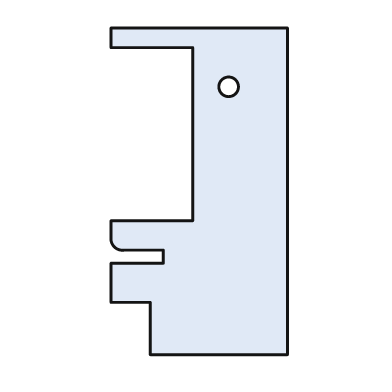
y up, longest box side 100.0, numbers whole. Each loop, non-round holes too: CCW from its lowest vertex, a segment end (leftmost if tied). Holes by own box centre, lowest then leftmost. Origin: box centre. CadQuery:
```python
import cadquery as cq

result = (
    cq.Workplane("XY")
    .moveTo(-15.0, -50.0)
    .lineTo(27.0, -50.0)
    .lineTo(27.0, 50.0)
    .lineTo(-27.0, 50.0)
    .lineTo(-27.0, 44.0)
    .lineTo(-2.0, 44.0)
    .lineTo(-2.0, -9.0)
    .lineTo(-27.0, -9.0)
    .lineTo(-27.0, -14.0)
    .threePointArc((-26.0, -17.0), (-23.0, -18.0))
    .lineTo(-11.0, -18.0)
    .lineTo(-11.0, -22.0)
    .lineTo(-27.0, -22.0)
    .lineTo(-27.0, -34.0)
    .lineTo(-15.0, -34.0)
    .close()
    .moveTo(9.0, 32.0)
    .circle(3.0)
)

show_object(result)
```